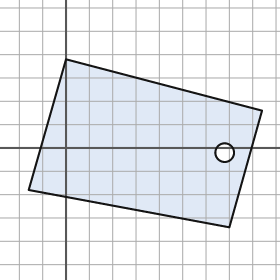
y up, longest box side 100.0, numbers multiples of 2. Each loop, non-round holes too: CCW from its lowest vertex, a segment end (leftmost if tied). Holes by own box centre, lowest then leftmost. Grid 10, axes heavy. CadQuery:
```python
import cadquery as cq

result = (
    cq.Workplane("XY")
    .moveTo(70.0, -34.0)
    .lineTo(84.0, 16.0)
    .lineTo(0.0, 38.0)
    .lineTo(-16.0, -18.0)
    .close()
    .moveTo(68.0, -2.0)
    .circle(4.0)
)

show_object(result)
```